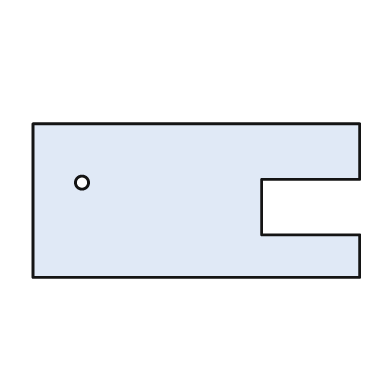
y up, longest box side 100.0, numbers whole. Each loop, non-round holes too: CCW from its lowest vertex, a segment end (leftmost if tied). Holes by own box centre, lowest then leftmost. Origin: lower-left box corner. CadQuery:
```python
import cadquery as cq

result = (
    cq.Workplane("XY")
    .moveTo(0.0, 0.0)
    .lineTo(100.0, 0.0)
    .lineTo(100.0, 13.0)
    .lineTo(70.0, 13.0)
    .lineTo(70.0, 30.0)
    .lineTo(100.0, 30.0)
    .lineTo(100.0, 47.0)
    .lineTo(0.0, 47.0)
    .close()
    .moveTo(15.0, 29.0)
    .circle(2.0)
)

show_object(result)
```